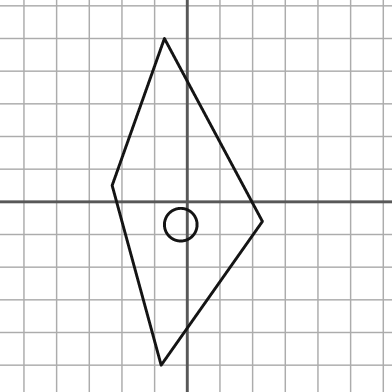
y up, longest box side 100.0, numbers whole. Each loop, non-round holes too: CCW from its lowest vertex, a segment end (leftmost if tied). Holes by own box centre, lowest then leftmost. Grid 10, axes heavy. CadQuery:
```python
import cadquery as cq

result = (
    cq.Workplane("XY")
    .moveTo(-8.0, -50.0)
    .lineTo(23.0, -6.0)
    .lineTo(-7.0, 50.0)
    .lineTo(-23.0, 5.0)
    .close()
    .moveTo(-2.0, -7.0)
    .circle(5.0)
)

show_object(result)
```